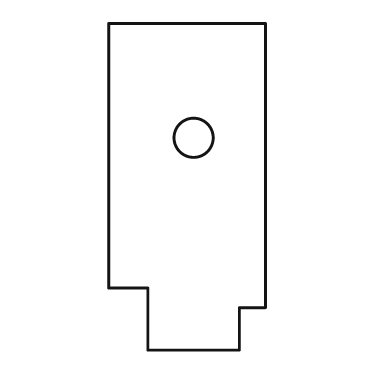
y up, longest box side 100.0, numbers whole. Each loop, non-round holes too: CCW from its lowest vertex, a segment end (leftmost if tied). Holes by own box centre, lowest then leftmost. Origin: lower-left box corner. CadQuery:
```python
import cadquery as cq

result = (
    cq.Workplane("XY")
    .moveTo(12.0, 0.0)
    .lineTo(40.0, 0.0)
    .lineTo(40.0, 13.0)
    .lineTo(48.0, 13.0)
    .lineTo(48.0, 100.0)
    .lineTo(0.0, 100.0)
    .lineTo(0.0, 19.0)
    .lineTo(12.0, 19.0)
    .close()
    .moveTo(26.0, 65.0)
    .circle(6.0)
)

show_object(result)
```